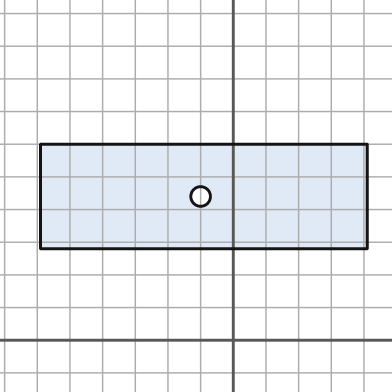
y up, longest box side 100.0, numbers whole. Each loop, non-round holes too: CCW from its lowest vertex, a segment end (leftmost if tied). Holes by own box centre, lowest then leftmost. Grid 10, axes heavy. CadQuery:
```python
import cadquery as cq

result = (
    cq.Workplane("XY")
    .moveTo(-59.0, 28.0)
    .lineTo(41.0, 28.0)
    .lineTo(41.0, 60.0)
    .lineTo(-59.0, 60.0)
    .close()
    .moveTo(-10.0, 44.0)
    .circle(3.0)
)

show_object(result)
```